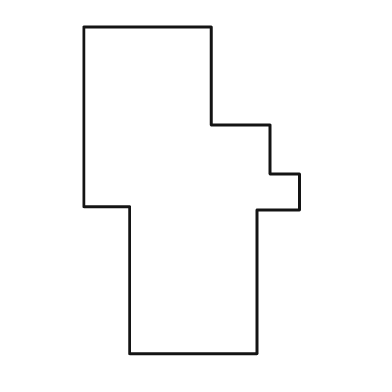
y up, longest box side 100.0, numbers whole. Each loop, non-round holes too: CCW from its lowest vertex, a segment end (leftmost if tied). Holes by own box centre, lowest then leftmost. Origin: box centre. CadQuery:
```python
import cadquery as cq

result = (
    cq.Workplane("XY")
    .moveTo(-19.0, -50.0)
    .lineTo(20.0, -50.0)
    .lineTo(20.0, -6.0)
    .lineTo(33.0, -6.0)
    .lineTo(33.0, 5.0)
    .lineTo(24.0, 5.0)
    .lineTo(24.0, 20.0)
    .lineTo(6.0, 20.0)
    .lineTo(6.0, 50.0)
    .lineTo(-33.0, 50.0)
    .lineTo(-33.0, -5.0)
    .lineTo(-19.0, -5.0)
    .close()
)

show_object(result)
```